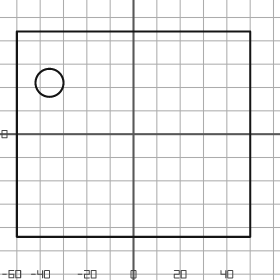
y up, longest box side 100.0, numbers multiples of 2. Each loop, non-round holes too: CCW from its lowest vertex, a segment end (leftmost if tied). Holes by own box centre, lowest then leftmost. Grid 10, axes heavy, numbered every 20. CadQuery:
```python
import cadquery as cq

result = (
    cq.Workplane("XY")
    .moveTo(-50.0, -44.0)
    .lineTo(50.0, -44.0)
    .lineTo(50.0, 44.0)
    .lineTo(-50.0, 44.0)
    .close()
    .moveTo(-36.0, 22.0)
    .circle(6.0)
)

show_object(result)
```